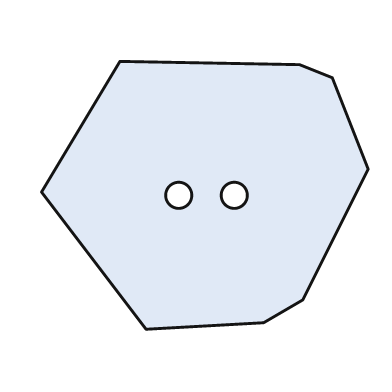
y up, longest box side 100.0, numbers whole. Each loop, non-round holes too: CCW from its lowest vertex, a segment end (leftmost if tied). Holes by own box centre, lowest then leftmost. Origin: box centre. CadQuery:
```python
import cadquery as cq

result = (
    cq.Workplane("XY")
    .moveTo(-18.0, -41.0)
    .lineTo(18.0, -39.0)
    .lineTo(30.0, -32.0)
    .lineTo(50.0, 8.0)
    .lineTo(39.0, 36.0)
    .lineTo(29.0, 40.0)
    .lineTo(-26.0, 41.0)
    .lineTo(-50.0, 1.0)
    .close()
    .moveTo(-8.0, 0.0)
    .circle(4.0)
    .moveTo(9.0, 0.0)
    .circle(4.0)
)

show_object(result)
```